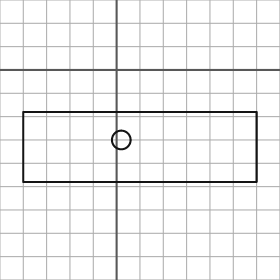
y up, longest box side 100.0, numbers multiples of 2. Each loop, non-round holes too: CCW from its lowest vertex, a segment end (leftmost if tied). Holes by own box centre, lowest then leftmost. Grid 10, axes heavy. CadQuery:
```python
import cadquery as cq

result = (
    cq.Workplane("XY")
    .moveTo(-40.0, -48.0)
    .lineTo(60.0, -48.0)
    .lineTo(60.0, -18.0)
    .lineTo(-40.0, -18.0)
    .close()
    .moveTo(2.0, -30.0)
    .circle(4.0)
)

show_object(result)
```